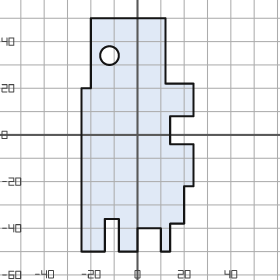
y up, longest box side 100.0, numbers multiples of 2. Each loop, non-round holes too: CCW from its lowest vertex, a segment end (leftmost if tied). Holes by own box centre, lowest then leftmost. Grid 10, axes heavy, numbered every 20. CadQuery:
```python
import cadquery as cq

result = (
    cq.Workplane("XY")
    .moveTo(-24.0, -50.0)
    .lineTo(-14.0, -50.0)
    .lineTo(-14.0, -36.0)
    .lineTo(-8.0, -36.0)
    .lineTo(-8.0, -50.0)
    .lineTo(0.0, -50.0)
    .lineTo(0.0, -40.0)
    .lineTo(10.0, -40.0)
    .lineTo(10.0, -50.0)
    .lineTo(14.0, -50.0)
    .lineTo(14.0, -38.0)
    .lineTo(20.0, -38.0)
    .lineTo(20.0, -22.0)
    .lineTo(24.0, -22.0)
    .lineTo(24.0, -4.0)
    .lineTo(14.0, -4.0)
    .lineTo(14.0, 8.0)
    .lineTo(24.0, 8.0)
    .lineTo(24.0, 22.0)
    .lineTo(12.0, 22.0)
    .lineTo(12.0, 50.0)
    .lineTo(-20.0, 50.0)
    .lineTo(-20.0, 20.0)
    .lineTo(-24.0, 20.0)
    .close()
    .moveTo(-12.0, 34.0)
    .circle(4.0)
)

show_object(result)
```